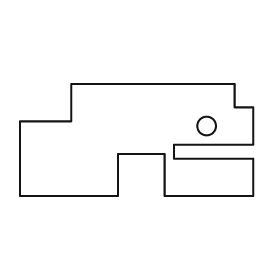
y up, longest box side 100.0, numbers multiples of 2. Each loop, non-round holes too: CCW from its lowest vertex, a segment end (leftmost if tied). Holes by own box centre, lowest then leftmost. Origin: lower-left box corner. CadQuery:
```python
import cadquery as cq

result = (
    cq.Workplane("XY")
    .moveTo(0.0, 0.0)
    .lineTo(42.0, 0.0)
    .lineTo(42.0, 18.0)
    .lineTo(62.0, 18.0)
    .lineTo(62.0, 0.0)
    .lineTo(100.0, 0.0)
    .lineTo(100.0, 16.0)
    .lineTo(66.0, 16.0)
    .lineTo(66.0, 22.0)
    .lineTo(100.0, 22.0)
    .lineTo(100.0, 38.0)
    .lineTo(92.0, 38.0)
    .lineTo(92.0, 48.0)
    .lineTo(22.0, 48.0)
    .lineTo(22.0, 32.0)
    .lineTo(0.0, 32.0)
    .close()
    .moveTo(80.0, 30.0)
    .circle(4.0)
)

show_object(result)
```